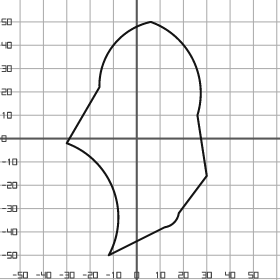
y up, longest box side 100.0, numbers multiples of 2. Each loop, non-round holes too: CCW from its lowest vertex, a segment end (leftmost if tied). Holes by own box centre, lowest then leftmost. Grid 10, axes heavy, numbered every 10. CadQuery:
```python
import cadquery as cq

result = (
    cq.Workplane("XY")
    .moveTo(-12.0, -50.0)
    .lineTo(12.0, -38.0)
    .threePointArc((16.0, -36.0), (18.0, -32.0))
    .lineTo(30.0, -16.0)
    .lineTo(26.0, 10.0)
    .threePointArc((24.0, 34.0), (6.0, 50.0))
    .threePointArc((-10.0, 40.0), (-16.0, 22.0))
    .lineTo(-30.0, -2.0)
    .threePointArc((-10.0, -22.0), (-12.0, -50.0))
    .close()
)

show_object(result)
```